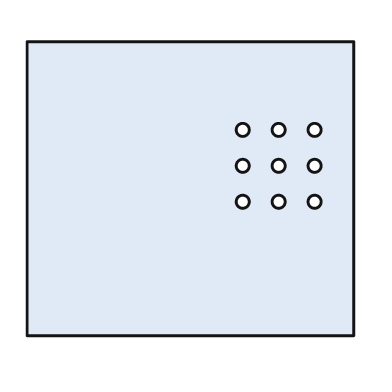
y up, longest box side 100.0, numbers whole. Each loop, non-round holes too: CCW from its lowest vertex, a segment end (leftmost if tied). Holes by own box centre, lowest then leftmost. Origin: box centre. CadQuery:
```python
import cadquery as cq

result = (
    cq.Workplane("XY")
    .moveTo(-50.0, -45.0)
    .lineTo(50.0, -45.0)
    .lineTo(50.0, 45.0)
    .lineTo(-50.0, 45.0)
    .close()
    .moveTo(16.0, -4.0)
    .circle(2.0)
    .moveTo(27.0, -4.0)
    .circle(2.0)
    .moveTo(38.0, -4.0)
    .circle(2.0)
    .moveTo(16.0, 7.0)
    .circle(2.0)
    .moveTo(27.0, 7.0)
    .circle(2.0)
    .moveTo(38.0, 7.0)
    .circle(2.0)
    .moveTo(16.0, 18.0)
    .circle(2.0)
    .moveTo(27.0, 18.0)
    .circle(2.0)
    .moveTo(38.0, 18.0)
    .circle(2.0)
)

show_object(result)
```